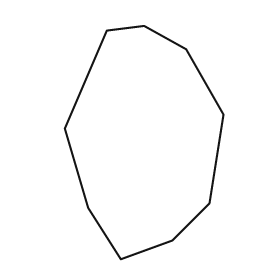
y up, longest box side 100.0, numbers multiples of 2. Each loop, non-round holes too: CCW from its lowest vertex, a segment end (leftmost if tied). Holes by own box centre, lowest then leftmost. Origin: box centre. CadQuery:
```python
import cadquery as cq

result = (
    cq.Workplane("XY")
    .moveTo(-10.0, -50.0)
    .lineTo(12.0, -42.0)
    .lineTo(28.0, -26.0)
    .lineTo(34.0, 12.0)
    .lineTo(18.0, 40.0)
    .lineTo(0.0, 50.0)
    .lineTo(-16.0, 48.0)
    .lineTo(-34.0, 6.0)
    .lineTo(-24.0, -28.0)
    .close()
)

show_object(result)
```